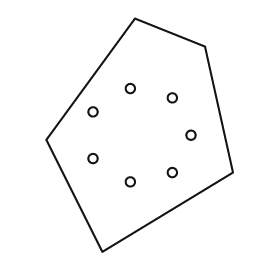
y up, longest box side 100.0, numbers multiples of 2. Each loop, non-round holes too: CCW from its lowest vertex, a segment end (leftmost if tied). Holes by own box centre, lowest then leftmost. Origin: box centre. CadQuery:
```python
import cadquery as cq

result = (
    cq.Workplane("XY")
    .moveTo(-16.0, -50.0)
    .lineTo(40.0, -16.0)
    .lineTo(28.0, 38.0)
    .lineTo(-2.0, 50.0)
    .lineTo(-40.0, -2.0)
    .close()
    .moveTo(-4.0, -20.0)
    .circle(2.0)
    .moveTo(14.0, -16.0)
    .circle(2.0)
    .moveTo(-20.0, -10.0)
    .circle(2.0)
    .moveTo(22.0, 0.0)
    .circle(2.0)
    .moveTo(-20.0, 10.0)
    .circle(2.0)
    .moveTo(14.0, 16.0)
    .circle(2.0)
    .moveTo(-4.0, 20.0)
    .circle(2.0)
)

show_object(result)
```